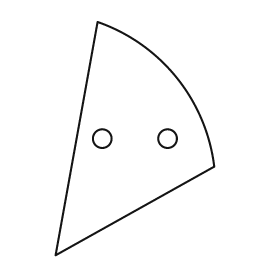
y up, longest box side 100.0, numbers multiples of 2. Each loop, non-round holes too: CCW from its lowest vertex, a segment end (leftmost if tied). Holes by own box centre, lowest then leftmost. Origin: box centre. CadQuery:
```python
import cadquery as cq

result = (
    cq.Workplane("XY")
    .moveTo(-34.0, -50.0)
    .lineTo(34.0, -12.0)
    .threePointArc((18.0, 26.0), (-16.0, 50.0))
    .close()
    .moveTo(-14.0, 0.0)
    .circle(4.0)
    .moveTo(14.0, 0.0)
    .circle(4.0)
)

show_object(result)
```